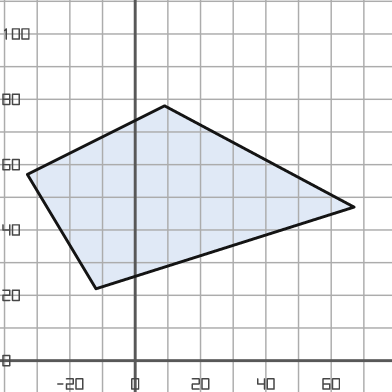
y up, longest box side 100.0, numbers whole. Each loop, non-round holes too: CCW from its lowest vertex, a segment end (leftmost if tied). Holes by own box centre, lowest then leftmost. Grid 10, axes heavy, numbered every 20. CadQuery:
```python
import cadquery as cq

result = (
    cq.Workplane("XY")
    .moveTo(-12.0, 22.0)
    .lineTo(67.0, 47.0)
    .lineTo(9.0, 78.0)
    .lineTo(-33.0, 57.0)
    .close()
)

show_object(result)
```